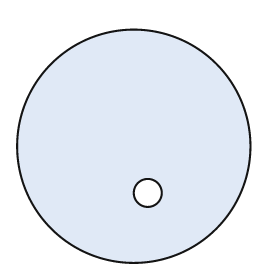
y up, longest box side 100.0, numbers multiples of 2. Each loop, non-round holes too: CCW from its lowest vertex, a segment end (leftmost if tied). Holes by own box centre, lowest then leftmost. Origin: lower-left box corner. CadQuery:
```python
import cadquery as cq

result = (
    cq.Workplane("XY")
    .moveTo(50.0, 50.0)
    .circle(50.0)
    .moveTo(56.0, 30.0)
    .circle(6.0)
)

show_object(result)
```